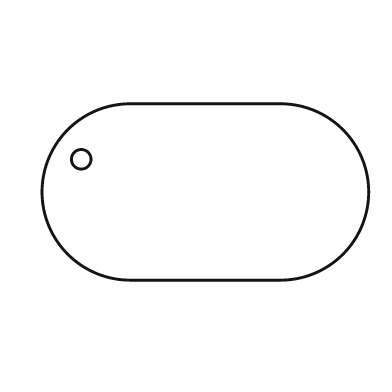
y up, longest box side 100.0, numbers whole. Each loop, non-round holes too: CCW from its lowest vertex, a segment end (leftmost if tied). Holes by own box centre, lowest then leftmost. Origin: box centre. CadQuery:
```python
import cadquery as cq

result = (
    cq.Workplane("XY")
    .moveTo(-23.0, -27.0)
    .lineTo(23.0, -27.0)
    .threePointArc((50.0, 0.0), (23.0, 27.0))
    .lineTo(-23.0, 27.0)
    .threePointArc((-50.0, 0.0), (-23.0, -27.0))
    .close()
    .moveTo(-38.0, 10.0)
    .circle(3.0)
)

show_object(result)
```